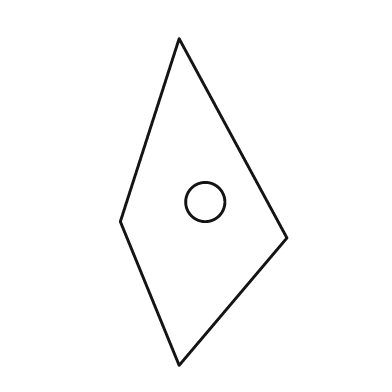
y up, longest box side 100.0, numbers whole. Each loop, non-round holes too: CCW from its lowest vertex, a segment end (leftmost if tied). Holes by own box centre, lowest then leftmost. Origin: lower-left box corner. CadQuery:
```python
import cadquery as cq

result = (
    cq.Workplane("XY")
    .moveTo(18.0, 0.0)
    .lineTo(51.0, 39.0)
    .lineTo(18.0, 100.0)
    .lineTo(0.0, 44.0)
    .close()
    .moveTo(26.0, 50.0)
    .circle(6.0)
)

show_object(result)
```